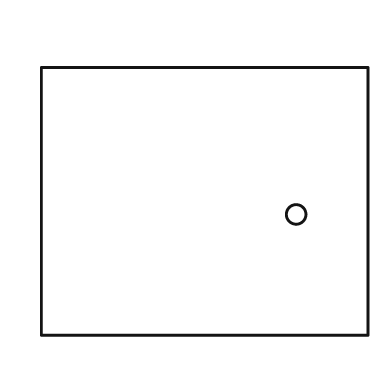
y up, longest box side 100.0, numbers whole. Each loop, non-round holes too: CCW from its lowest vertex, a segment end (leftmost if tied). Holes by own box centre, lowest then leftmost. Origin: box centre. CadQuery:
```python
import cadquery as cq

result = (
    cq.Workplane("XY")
    .moveTo(-50.0, -41.0)
    .lineTo(50.0, -41.0)
    .lineTo(50.0, 41.0)
    .lineTo(-50.0, 41.0)
    .close()
    .moveTo(28.0, -4.0)
    .circle(3.0)
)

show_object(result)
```